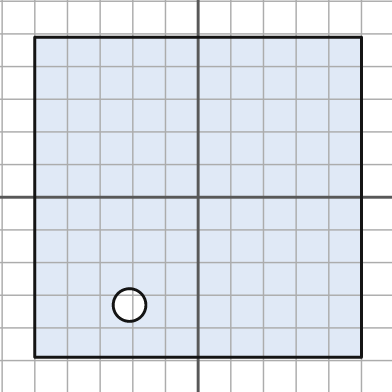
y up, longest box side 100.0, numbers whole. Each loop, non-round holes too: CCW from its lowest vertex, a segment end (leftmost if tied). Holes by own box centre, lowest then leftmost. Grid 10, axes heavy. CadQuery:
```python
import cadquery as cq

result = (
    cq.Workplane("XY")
    .moveTo(-50.0, -49.0)
    .lineTo(50.0, -49.0)
    .lineTo(50.0, 49.0)
    .lineTo(-50.0, 49.0)
    .close()
    .moveTo(-21.0, -33.0)
    .circle(5.0)
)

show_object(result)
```